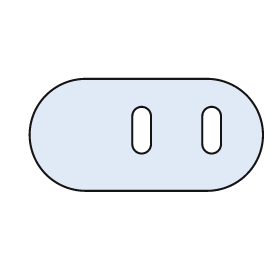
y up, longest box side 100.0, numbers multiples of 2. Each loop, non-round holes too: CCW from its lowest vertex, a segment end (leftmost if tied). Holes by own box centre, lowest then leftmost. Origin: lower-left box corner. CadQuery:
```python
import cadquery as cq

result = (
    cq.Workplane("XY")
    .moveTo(24.0, 0.0)
    .lineTo(76.0, 0.0)
    .threePointArc((100.0, 24.0), (76.0, 48.0))
    .lineTo(24.0, 48.0)
    .threePointArc((0.0, 24.0), (24.0, 0.0))
    .close()
    .moveTo(44.0, 20.0)
    .threePointArc((48.0, 16.0), (52.0, 20.0))
    .lineTo(52.0, 32.0)
    .threePointArc((48.0, 36.0), (44.0, 32.0))
    .close()
    .moveTo(74.0, 20.0)
    .threePointArc((78.0, 16.0), (82.0, 20.0))
    .lineTo(82.0, 32.0)
    .threePointArc((78.0, 36.0), (74.0, 32.0))
    .close()
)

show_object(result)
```